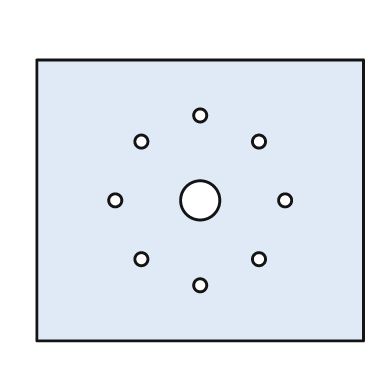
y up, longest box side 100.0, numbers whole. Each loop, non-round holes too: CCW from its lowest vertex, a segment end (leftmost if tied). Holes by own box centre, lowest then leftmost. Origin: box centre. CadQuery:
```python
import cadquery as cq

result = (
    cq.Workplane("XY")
    .moveTo(-50.0, -43.0)
    .lineTo(50.0, -43.0)
    .lineTo(50.0, 43.0)
    .lineTo(-50.0, 43.0)
    .close()
    .moveTo(0.0, -26.0)
    .circle(2.0)
    .moveTo(-18.0, -18.0)
    .circle(2.0)
    .moveTo(18.0, -18.0)
    .circle(2.0)
    .moveTo(-26.0, 0.0)
    .circle(2.0)
    .moveTo(0.0, 0.0)
    .circle(6.0)
    .moveTo(26.0, 0.0)
    .circle(2.0)
    .moveTo(-18.0, 18.0)
    .circle(2.0)
    .moveTo(18.0, 18.0)
    .circle(2.0)
    .moveTo(0.0, 26.0)
    .circle(2.0)
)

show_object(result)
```